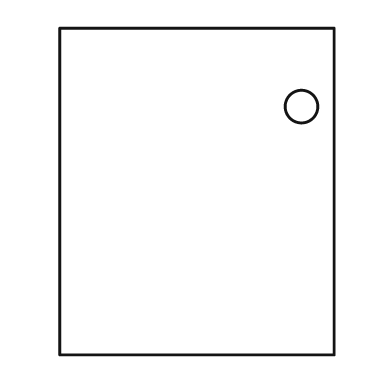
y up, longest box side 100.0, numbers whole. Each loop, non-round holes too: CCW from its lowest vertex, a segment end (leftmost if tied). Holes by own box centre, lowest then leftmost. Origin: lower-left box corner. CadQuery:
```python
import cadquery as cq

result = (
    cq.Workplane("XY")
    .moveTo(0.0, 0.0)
    .lineTo(84.0, 0.0)
    .lineTo(84.0, 100.0)
    .lineTo(0.0, 100.0)
    .close()
    .moveTo(74.0, 76.0)
    .circle(5.0)
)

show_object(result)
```